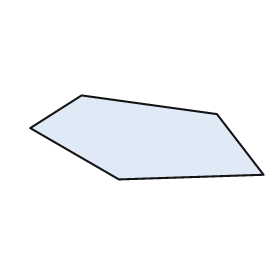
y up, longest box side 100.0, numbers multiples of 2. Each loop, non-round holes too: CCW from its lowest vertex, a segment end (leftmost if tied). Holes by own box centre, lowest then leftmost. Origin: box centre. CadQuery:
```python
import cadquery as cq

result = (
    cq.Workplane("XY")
    .moveTo(-12.0, -18.0)
    .lineTo(50.0, -16.0)
    .lineTo(30.0, 10.0)
    .lineTo(-28.0, 18.0)
    .lineTo(-50.0, 4.0)
    .close()
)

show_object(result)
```